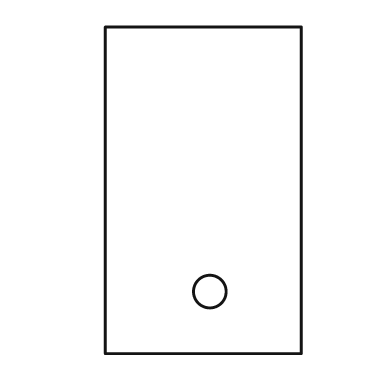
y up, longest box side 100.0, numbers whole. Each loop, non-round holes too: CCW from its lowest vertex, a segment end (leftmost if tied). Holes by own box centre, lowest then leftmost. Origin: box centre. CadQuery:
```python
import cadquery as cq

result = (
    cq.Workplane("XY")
    .moveTo(-30.0, -50.0)
    .lineTo(30.0, -50.0)
    .lineTo(30.0, 50.0)
    .lineTo(-30.0, 50.0)
    .close()
    .moveTo(2.0, -31.0)
    .circle(5.0)
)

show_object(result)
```